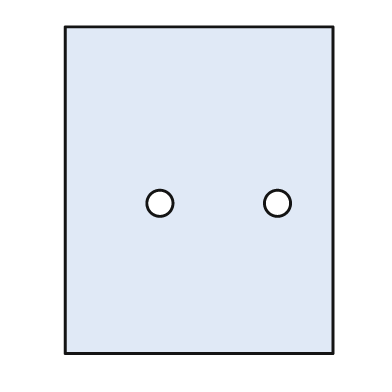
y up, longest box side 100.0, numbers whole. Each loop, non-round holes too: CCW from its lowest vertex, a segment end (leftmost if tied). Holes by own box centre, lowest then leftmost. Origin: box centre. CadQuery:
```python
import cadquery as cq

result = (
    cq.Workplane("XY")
    .moveTo(-41.0, -50.0)
    .lineTo(41.0, -50.0)
    .lineTo(41.0, 50.0)
    .lineTo(-41.0, 50.0)
    .close()
    .moveTo(-12.0, -4.0)
    .circle(4.0)
    .moveTo(24.0, -4.0)
    .circle(4.0)
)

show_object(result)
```